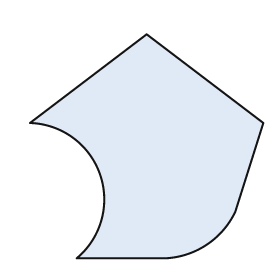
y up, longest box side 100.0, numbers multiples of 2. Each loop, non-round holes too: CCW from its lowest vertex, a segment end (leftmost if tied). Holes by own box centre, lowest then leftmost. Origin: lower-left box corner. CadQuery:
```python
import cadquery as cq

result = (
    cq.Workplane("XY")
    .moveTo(20.0, 0.0)
    .lineTo(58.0, 0.0)
    .threePointArc((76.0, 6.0), (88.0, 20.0))
    .lineTo(100.0, 58.0)
    .lineTo(50.0, 96.0)
    .lineTo(0.0, 58.0)
    .threePointArc((30.0, 36.0), (20.0, 0.0))
    .close()
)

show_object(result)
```